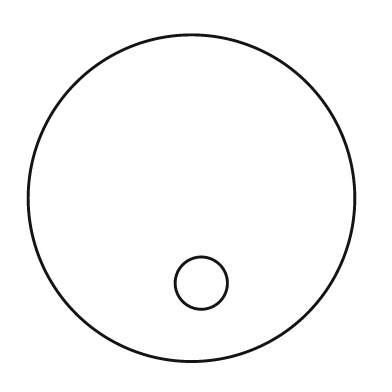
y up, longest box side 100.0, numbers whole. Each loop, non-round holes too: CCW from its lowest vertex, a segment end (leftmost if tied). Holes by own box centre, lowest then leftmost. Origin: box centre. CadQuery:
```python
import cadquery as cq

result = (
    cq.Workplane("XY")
    .moveTo(0.0, 0.0)
    .circle(50.0)
    .moveTo(3.0, -26.0)
    .circle(8.0)
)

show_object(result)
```